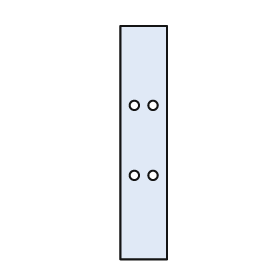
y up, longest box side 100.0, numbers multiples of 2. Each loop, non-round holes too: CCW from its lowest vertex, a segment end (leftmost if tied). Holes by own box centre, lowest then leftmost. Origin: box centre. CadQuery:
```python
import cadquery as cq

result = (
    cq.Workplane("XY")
    .moveTo(-10.0, -50.0)
    .lineTo(10.0, -50.0)
    .lineTo(10.0, 50.0)
    .lineTo(-10.0, 50.0)
    .close()
    .moveTo(-4.0, -14.0)
    .circle(2.0)
    .moveTo(4.0, -14.0)
    .circle(2.0)
    .moveTo(-4.0, 16.0)
    .circle(2.0)
    .moveTo(4.0, 16.0)
    .circle(2.0)
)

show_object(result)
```